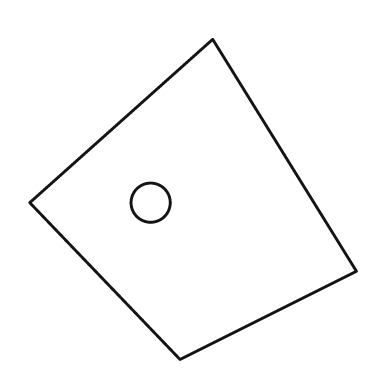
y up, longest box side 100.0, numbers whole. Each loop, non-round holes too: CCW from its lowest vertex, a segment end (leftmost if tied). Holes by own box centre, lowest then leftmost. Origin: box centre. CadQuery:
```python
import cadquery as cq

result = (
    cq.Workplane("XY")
    .moveTo(-4.0, -49.0)
    .lineTo(50.0, -22.0)
    .lineTo(6.0, 49.0)
    .lineTo(-50.0, -1.0)
    .close()
    .moveTo(-13.0, -1.0)
    .circle(6.0)
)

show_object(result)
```